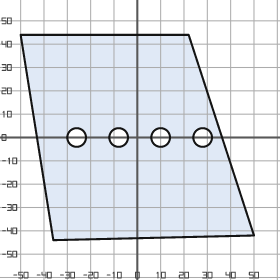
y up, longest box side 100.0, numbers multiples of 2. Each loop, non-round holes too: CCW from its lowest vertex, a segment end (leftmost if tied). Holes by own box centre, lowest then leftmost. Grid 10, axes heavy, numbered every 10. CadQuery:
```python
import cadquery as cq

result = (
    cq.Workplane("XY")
    .moveTo(-36.0, -44.0)
    .lineTo(50.0, -42.0)
    .lineTo(22.0, 44.0)
    .lineTo(-50.0, 44.0)
    .close()
    .moveTo(-26.0, 0.0)
    .circle(4.0)
    .moveTo(-8.0, 0.0)
    .circle(4.0)
    .moveTo(10.0, 0.0)
    .circle(4.0)
    .moveTo(28.0, 0.0)
    .circle(4.0)
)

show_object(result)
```